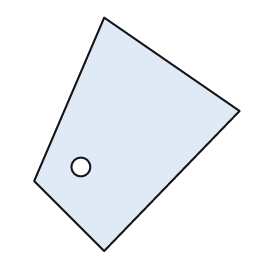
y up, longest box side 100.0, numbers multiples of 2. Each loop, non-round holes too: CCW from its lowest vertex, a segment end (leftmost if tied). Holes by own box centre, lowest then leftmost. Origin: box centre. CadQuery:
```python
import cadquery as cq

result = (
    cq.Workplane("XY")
    .moveTo(-14.0, -50.0)
    .lineTo(44.0, 10.0)
    .lineTo(-14.0, 50.0)
    .lineTo(-44.0, -20.0)
    .close()
    .moveTo(-24.0, -14.0)
    .circle(4.0)
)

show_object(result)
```